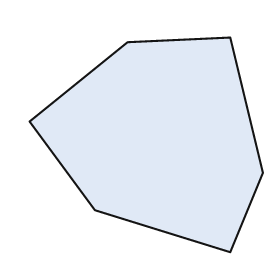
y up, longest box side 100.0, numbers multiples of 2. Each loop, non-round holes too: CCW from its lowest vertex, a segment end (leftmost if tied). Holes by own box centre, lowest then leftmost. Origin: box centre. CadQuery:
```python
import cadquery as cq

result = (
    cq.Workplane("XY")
    .moveTo(36.0, -46.0)
    .lineTo(50.0, -12.0)
    .lineTo(36.0, 46.0)
    .lineTo(-8.0, 44.0)
    .lineTo(-50.0, 10.0)
    .lineTo(-22.0, -28.0)
    .close()
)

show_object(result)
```